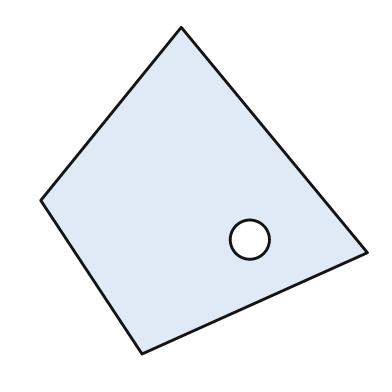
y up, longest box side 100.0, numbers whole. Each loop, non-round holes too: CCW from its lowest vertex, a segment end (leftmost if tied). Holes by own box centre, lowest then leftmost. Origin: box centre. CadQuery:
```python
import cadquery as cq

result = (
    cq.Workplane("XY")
    .moveTo(-19.0, -50.0)
    .lineTo(50.0, -19.0)
    .lineTo(-7.0, 50.0)
    .lineTo(-50.0, -3.0)
    .close()
    .moveTo(14.0, -15.0)
    .circle(6.0)
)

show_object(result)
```